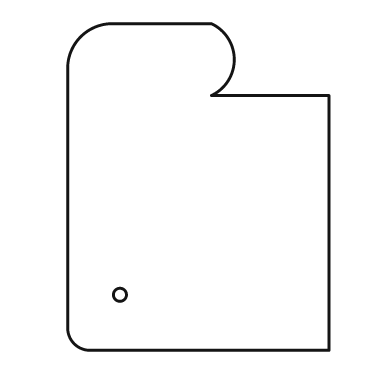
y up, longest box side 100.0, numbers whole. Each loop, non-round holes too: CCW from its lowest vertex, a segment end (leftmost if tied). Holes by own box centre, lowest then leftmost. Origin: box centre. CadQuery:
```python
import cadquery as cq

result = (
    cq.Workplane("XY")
    .moveTo(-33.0, -50.0)
    .lineTo(40.0, -50.0)
    .lineTo(40.0, 28.0)
    .lineTo(4.0, 28.0)
    .threePointArc((11.0, 39.0), (4.0, 50.0))
    .lineTo(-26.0, 50.0)
    .threePointArc((-36.0, 46.0), (-40.0, 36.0))
    .lineTo(-40.0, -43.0)
    .threePointArc((-38.0, -48.0), (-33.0, -50.0))
    .close()
    .moveTo(-24.0, -33.0)
    .circle(2.0)
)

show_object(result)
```